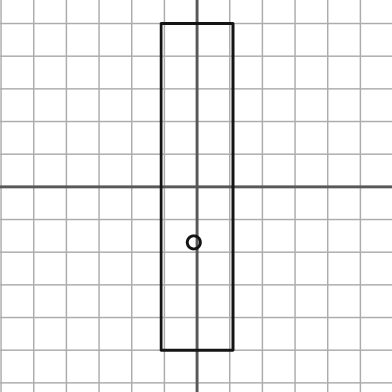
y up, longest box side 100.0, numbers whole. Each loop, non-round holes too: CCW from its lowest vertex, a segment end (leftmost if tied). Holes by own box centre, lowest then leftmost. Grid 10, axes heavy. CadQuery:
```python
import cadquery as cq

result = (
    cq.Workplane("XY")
    .moveTo(-11.0, -50.0)
    .lineTo(11.0, -50.0)
    .lineTo(11.0, 50.0)
    .lineTo(-11.0, 50.0)
    .close()
    .moveTo(-1.0, -17.0)
    .circle(2.0)
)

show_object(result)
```